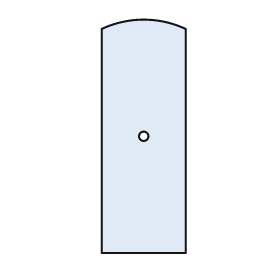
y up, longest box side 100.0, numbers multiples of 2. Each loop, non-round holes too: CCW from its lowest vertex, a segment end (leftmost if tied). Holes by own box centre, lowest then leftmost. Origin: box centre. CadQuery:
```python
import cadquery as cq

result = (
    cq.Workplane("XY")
    .moveTo(-18.0, -50.0)
    .lineTo(18.0, -50.0)
    .lineTo(18.0, 46.0)
    .threePointArc((0.0, 50.0), (-18.0, 46.0))
    .close()
    .moveTo(0.0, 0.0)
    .circle(2.0)
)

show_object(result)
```